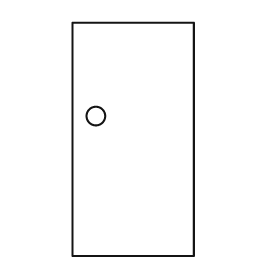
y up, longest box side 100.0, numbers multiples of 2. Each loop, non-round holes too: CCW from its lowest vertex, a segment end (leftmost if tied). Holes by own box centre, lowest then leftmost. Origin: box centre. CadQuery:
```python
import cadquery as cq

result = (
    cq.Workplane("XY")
    .moveTo(-26.0, -50.0)
    .lineTo(26.0, -50.0)
    .lineTo(26.0, 50.0)
    .lineTo(-26.0, 50.0)
    .close()
    .moveTo(-16.0, 10.0)
    .circle(4.0)
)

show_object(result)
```